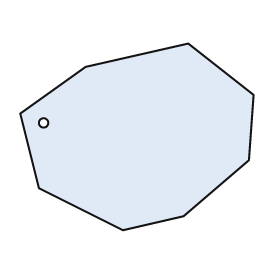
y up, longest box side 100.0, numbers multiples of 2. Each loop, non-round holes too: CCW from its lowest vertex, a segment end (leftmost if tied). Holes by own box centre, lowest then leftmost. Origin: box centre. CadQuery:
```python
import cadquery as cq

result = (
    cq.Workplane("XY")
    .moveTo(-6.0, -40.0)
    .lineTo(20.0, -34.0)
    .lineTo(48.0, -10.0)
    .lineTo(50.0, 18.0)
    .lineTo(22.0, 40.0)
    .lineTo(-22.0, 30.0)
    .lineTo(-50.0, 10.0)
    .lineTo(-42.0, -22.0)
    .close()
    .moveTo(-40.0, 6.0)
    .circle(2.0)
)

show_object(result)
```